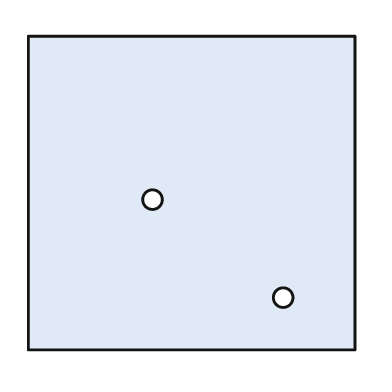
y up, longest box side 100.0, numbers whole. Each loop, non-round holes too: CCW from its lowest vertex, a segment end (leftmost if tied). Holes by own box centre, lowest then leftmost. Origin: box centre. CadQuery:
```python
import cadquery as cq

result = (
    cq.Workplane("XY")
    .moveTo(-50.0, -48.0)
    .lineTo(50.0, -48.0)
    .lineTo(50.0, 48.0)
    .lineTo(-50.0, 48.0)
    .close()
    .moveTo(28.0, -32.0)
    .circle(3.0)
    .moveTo(-12.0, -2.0)
    .circle(3.0)
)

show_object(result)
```